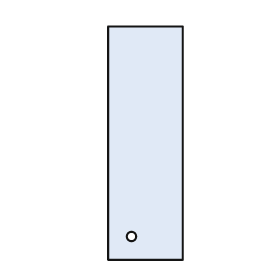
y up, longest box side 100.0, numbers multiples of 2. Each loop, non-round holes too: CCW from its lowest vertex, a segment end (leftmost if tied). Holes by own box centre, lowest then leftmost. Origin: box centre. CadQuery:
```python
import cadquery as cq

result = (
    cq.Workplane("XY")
    .moveTo(-16.0, -50.0)
    .lineTo(16.0, -50.0)
    .lineTo(16.0, 50.0)
    .lineTo(-16.0, 50.0)
    .close()
    .moveTo(-6.0, -40.0)
    .circle(2.0)
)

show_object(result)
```